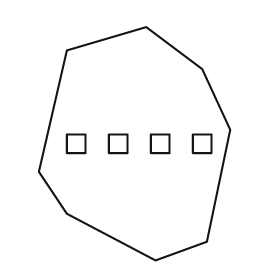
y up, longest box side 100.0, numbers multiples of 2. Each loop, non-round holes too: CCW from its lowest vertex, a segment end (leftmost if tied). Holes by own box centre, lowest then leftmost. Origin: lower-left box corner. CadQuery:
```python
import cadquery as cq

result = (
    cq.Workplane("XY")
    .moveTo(50.0, 0.0)
    .lineTo(72.0, 8.0)
    .lineTo(82.0, 56.0)
    .lineTo(70.0, 82.0)
    .lineTo(46.0, 100.0)
    .lineTo(12.0, 90.0)
    .lineTo(0.0, 38.0)
    .lineTo(12.0, 20.0)
    .close()
    .moveTo(12.0, 46.0)
    .lineTo(20.0, 46.0)
    .lineTo(20.0, 54.0)
    .lineTo(12.0, 54.0)
    .close()
    .moveTo(30.0, 46.0)
    .lineTo(38.0, 46.0)
    .lineTo(38.0, 54.0)
    .lineTo(30.0, 54.0)
    .close()
    .moveTo(48.0, 46.0)
    .lineTo(56.0, 46.0)
    .lineTo(56.0, 54.0)
    .lineTo(48.0, 54.0)
    .close()
    .moveTo(66.0, 46.0)
    .lineTo(74.0, 46.0)
    .lineTo(74.0, 54.0)
    .lineTo(66.0, 54.0)
    .close()
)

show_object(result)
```